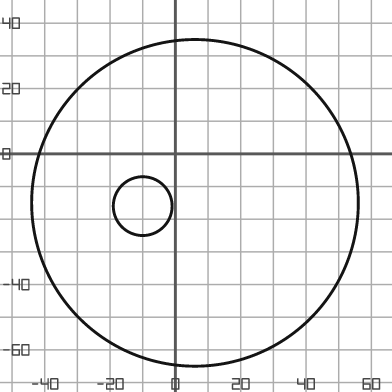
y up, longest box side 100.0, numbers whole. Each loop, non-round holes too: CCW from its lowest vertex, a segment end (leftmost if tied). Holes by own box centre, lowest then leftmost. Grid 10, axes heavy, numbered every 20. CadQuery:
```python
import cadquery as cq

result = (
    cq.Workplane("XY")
    .moveTo(6.0, -15.0)
    .circle(50.0)
    .moveTo(-10.0, -16.0)
    .circle(9.0)
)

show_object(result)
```